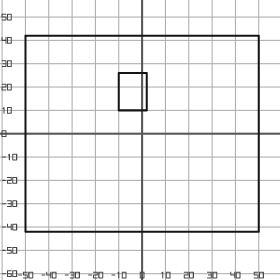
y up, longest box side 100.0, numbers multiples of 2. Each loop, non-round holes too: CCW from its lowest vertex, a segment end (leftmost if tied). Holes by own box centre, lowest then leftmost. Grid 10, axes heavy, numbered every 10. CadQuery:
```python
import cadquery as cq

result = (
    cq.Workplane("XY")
    .moveTo(-50.0, -42.0)
    .lineTo(50.0, -42.0)
    .lineTo(50.0, 42.0)
    .lineTo(-50.0, 42.0)
    .close()
    .moveTo(-10.0, 10.0)
    .lineTo(2.0, 10.0)
    .lineTo(2.0, 26.0)
    .lineTo(-10.0, 26.0)
    .close()
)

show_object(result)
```